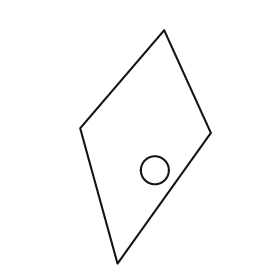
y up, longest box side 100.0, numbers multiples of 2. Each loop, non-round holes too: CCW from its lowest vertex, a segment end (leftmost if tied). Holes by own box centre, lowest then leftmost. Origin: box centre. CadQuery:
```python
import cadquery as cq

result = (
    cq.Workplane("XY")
    .moveTo(-12.0, -50.0)
    .lineTo(28.0, 6.0)
    .lineTo(8.0, 50.0)
    .lineTo(-28.0, 8.0)
    .close()
    .moveTo(4.0, -10.0)
    .circle(6.0)
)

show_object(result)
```